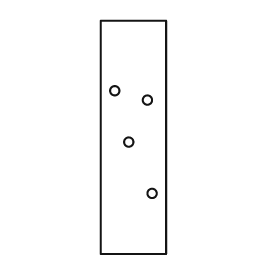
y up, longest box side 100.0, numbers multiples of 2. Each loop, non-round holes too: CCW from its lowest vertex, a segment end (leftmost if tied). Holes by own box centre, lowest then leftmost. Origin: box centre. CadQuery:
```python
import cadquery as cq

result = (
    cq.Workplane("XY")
    .moveTo(-14.0, -50.0)
    .lineTo(14.0, -50.0)
    .lineTo(14.0, 50.0)
    .lineTo(-14.0, 50.0)
    .close()
    .moveTo(8.0, -24.0)
    .circle(2.0)
    .moveTo(-2.0, -2.0)
    .circle(2.0)
    .moveTo(6.0, 16.0)
    .circle(2.0)
    .moveTo(-8.0, 20.0)
    .circle(2.0)
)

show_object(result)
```